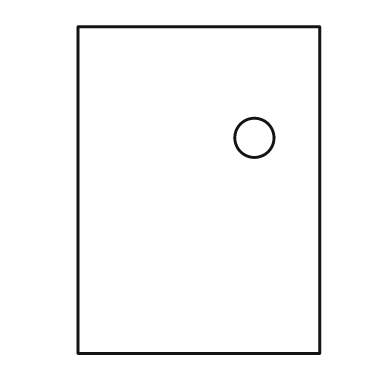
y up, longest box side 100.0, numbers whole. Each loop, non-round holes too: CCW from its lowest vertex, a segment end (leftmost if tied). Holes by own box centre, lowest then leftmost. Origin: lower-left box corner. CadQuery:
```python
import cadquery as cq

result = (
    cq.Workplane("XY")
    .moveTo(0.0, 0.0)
    .lineTo(74.0, 0.0)
    .lineTo(74.0, 100.0)
    .lineTo(0.0, 100.0)
    .close()
    .moveTo(54.0, 66.0)
    .circle(6.0)
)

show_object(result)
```